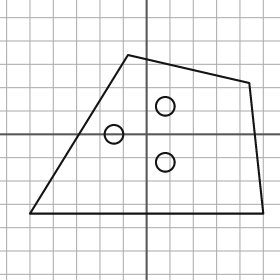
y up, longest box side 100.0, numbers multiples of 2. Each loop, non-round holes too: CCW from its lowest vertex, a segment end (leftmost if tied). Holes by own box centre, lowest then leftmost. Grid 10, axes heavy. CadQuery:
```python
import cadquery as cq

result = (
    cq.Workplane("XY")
    .moveTo(-50.0, -34.0)
    .lineTo(50.0, -34.0)
    .lineTo(44.0, 22.0)
    .lineTo(-8.0, 34.0)
    .close()
    .moveTo(8.0, -12.0)
    .circle(4.0)
    .moveTo(-14.0, 0.0)
    .circle(4.0)
    .moveTo(8.0, 12.0)
    .circle(4.0)
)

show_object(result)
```